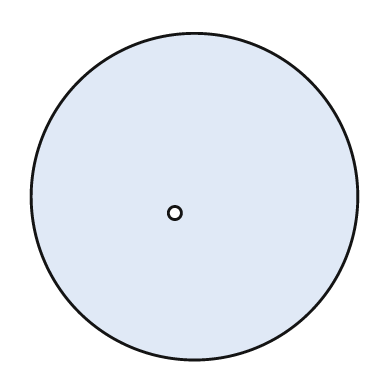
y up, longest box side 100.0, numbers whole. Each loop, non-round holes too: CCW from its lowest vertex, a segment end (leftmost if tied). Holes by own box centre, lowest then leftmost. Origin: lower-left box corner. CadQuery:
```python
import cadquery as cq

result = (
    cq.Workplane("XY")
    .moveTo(50.0, 50.0)
    .circle(50.0)
    .moveTo(44.0, 45.0)
    .circle(2.0)
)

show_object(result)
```